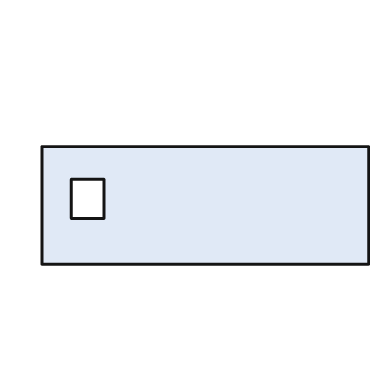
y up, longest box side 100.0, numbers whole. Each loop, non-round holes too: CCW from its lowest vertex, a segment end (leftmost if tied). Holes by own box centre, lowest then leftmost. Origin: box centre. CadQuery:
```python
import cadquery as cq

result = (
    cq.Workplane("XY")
    .moveTo(-50.0, -18.0)
    .lineTo(50.0, -18.0)
    .lineTo(50.0, 18.0)
    .lineTo(-50.0, 18.0)
    .close()
    .moveTo(-41.0, -4.0)
    .lineTo(-31.0, -4.0)
    .lineTo(-31.0, 8.0)
    .lineTo(-41.0, 8.0)
    .close()
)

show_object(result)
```